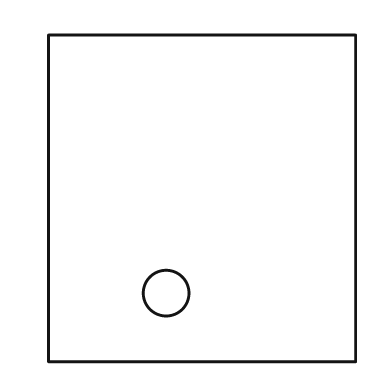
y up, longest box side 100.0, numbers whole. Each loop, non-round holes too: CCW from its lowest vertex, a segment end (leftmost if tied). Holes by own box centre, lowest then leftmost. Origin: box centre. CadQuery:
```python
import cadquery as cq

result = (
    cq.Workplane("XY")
    .moveTo(-47.0, -50.0)
    .lineTo(47.0, -50.0)
    .lineTo(47.0, 50.0)
    .lineTo(-47.0, 50.0)
    .close()
    .moveTo(-11.0, -29.0)
    .circle(7.0)
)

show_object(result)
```